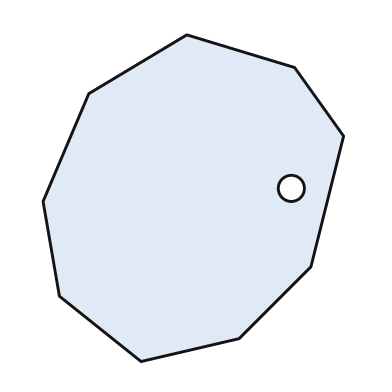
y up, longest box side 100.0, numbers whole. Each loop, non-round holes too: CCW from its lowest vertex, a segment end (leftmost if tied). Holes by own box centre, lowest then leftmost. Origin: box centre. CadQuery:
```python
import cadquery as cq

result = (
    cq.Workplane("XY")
    .moveTo(-16.0, -50.0)
    .lineTo(14.0, -43.0)
    .lineTo(36.0, -21.0)
    .lineTo(46.0, 19.0)
    .lineTo(31.0, 40.0)
    .lineTo(-2.0, 50.0)
    .lineTo(-32.0, 32.0)
    .lineTo(-46.0, -1.0)
    .lineTo(-41.0, -30.0)
    .close()
    .moveTo(30.0, 3.0)
    .circle(4.0)
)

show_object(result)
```